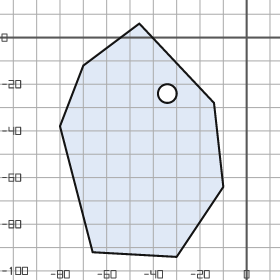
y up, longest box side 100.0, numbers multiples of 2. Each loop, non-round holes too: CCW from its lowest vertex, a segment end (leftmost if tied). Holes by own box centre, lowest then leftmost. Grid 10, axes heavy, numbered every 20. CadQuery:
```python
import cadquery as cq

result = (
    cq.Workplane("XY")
    .moveTo(-30.0, -94.0)
    .lineTo(-10.0, -64.0)
    .lineTo(-14.0, -28.0)
    .lineTo(-46.0, 6.0)
    .lineTo(-70.0, -12.0)
    .lineTo(-80.0, -38.0)
    .lineTo(-66.0, -92.0)
    .close()
    .moveTo(-34.0, -24.0)
    .circle(4.0)
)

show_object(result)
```